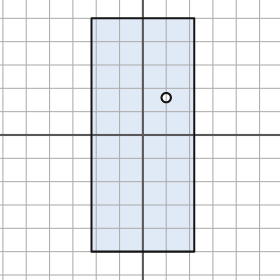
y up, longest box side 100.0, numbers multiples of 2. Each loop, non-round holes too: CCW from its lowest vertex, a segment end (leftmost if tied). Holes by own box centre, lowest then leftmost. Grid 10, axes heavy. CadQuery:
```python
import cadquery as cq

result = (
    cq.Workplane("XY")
    .moveTo(-22.0, -50.0)
    .lineTo(22.0, -50.0)
    .lineTo(22.0, 50.0)
    .lineTo(-22.0, 50.0)
    .close()
    .moveTo(10.0, 16.0)
    .circle(2.0)
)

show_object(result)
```